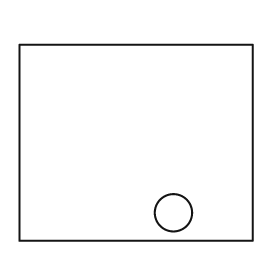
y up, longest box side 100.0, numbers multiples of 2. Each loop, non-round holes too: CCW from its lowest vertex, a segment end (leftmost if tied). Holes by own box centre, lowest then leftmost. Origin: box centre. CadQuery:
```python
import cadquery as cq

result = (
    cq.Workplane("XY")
    .moveTo(-50.0, -42.0)
    .lineTo(50.0, -42.0)
    .lineTo(50.0, 42.0)
    .lineTo(-50.0, 42.0)
    .close()
    .moveTo(16.0, -30.0)
    .circle(8.0)
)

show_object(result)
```